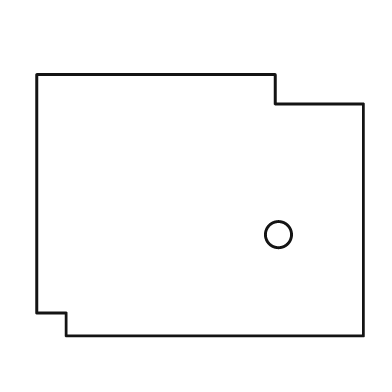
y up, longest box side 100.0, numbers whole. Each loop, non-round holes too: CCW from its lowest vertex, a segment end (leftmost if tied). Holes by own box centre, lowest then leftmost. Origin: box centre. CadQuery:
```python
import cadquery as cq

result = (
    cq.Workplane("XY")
    .moveTo(-41.0, -40.0)
    .lineTo(50.0, -40.0)
    .lineTo(50.0, 31.0)
    .lineTo(23.0, 31.0)
    .lineTo(23.0, 40.0)
    .lineTo(-50.0, 40.0)
    .lineTo(-50.0, -33.0)
    .lineTo(-41.0, -33.0)
    .close()
    .moveTo(24.0, -9.0)
    .circle(4.0)
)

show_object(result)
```